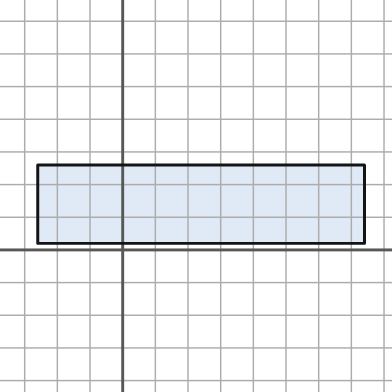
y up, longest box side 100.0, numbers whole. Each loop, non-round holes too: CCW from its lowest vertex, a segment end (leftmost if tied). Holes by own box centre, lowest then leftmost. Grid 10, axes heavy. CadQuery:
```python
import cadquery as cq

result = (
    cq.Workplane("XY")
    .moveTo(-26.0, 2.0)
    .lineTo(74.0, 2.0)
    .lineTo(74.0, 26.0)
    .lineTo(-26.0, 26.0)
    .close()
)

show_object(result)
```